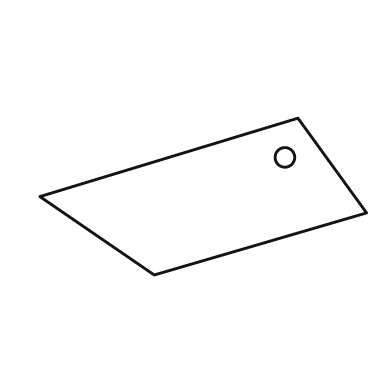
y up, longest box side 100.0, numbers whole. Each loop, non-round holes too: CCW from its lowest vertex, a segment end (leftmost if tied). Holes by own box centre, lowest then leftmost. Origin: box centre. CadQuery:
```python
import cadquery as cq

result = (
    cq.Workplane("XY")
    .moveTo(-15.0, -24.0)
    .lineTo(50.0, -5.0)
    .lineTo(29.0, 24.0)
    .lineTo(-50.0, 0.0)
    .close()
    .moveTo(25.0, 12.0)
    .circle(3.0)
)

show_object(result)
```